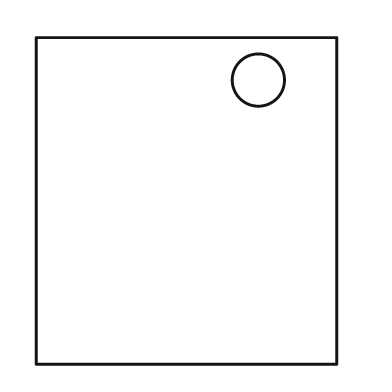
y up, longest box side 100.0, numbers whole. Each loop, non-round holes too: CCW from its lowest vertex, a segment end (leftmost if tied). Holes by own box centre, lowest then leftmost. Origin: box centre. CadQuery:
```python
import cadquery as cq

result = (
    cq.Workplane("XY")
    .moveTo(-46.0, -50.0)
    .lineTo(46.0, -50.0)
    .lineTo(46.0, 50.0)
    .lineTo(-46.0, 50.0)
    .close()
    .moveTo(22.0, 37.0)
    .circle(8.0)
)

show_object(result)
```